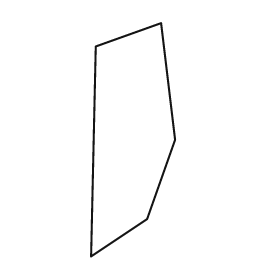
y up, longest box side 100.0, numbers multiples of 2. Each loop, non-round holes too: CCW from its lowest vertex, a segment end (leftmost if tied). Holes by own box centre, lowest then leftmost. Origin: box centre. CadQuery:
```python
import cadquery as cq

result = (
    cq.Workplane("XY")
    .moveTo(-18.0, -50.0)
    .lineTo(6.0, -34.0)
    .lineTo(18.0, 0.0)
    .lineTo(12.0, 50.0)
    .lineTo(-16.0, 40.0)
    .close()
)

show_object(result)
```